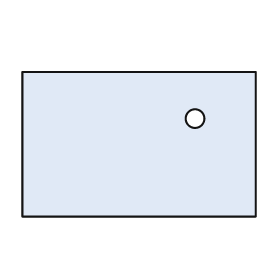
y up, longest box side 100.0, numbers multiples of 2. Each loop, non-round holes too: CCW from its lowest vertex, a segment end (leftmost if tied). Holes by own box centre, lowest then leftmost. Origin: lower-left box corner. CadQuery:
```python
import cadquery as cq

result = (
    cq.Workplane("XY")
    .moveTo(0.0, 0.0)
    .lineTo(100.0, 0.0)
    .lineTo(100.0, 62.0)
    .lineTo(0.0, 62.0)
    .close()
    .moveTo(74.0, 42.0)
    .circle(4.0)
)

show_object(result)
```